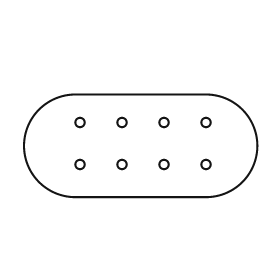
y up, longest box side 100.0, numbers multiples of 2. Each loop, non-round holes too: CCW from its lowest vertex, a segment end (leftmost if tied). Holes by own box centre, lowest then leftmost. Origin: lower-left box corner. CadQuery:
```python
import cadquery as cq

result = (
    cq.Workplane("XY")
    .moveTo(22.0, 0.0)
    .lineTo(78.0, 0.0)
    .threePointArc((100.0, 22.0), (78.0, 44.0))
    .lineTo(22.0, 44.0)
    .threePointArc((0.0, 22.0), (22.0, 0.0))
    .close()
    .moveTo(24.0, 14.0)
    .circle(2.0)
    .moveTo(42.0, 14.0)
    .circle(2.0)
    .moveTo(60.0, 14.0)
    .circle(2.0)
    .moveTo(78.0, 14.0)
    .circle(2.0)
    .moveTo(24.0, 32.0)
    .circle(2.0)
    .moveTo(42.0, 32.0)
    .circle(2.0)
    .moveTo(60.0, 32.0)
    .circle(2.0)
    .moveTo(78.0, 32.0)
    .circle(2.0)
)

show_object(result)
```